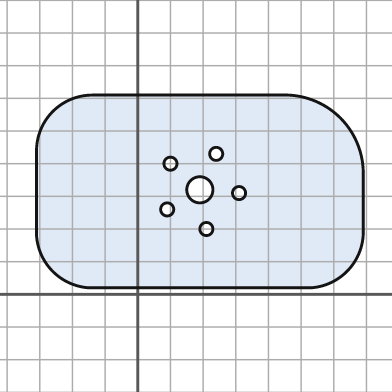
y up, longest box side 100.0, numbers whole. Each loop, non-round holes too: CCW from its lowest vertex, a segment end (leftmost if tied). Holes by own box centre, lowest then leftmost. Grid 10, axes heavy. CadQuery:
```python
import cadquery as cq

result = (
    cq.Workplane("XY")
    .moveTo(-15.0, 2.0)
    .lineTo(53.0, 2.0)
    .threePointArc((64.0, 7.0), (69.0, 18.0))
    .lineTo(69.0, 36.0)
    .threePointArc((62.0, 54.0), (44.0, 61.0))
    .lineTo(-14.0, 61.0)
    .threePointArc((-26.0, 56.0), (-31.0, 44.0))
    .lineTo(-31.0, 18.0)
    .threePointArc((-26.0, 7.0), (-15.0, 2.0))
    .close()
    .moveTo(21.0, 20.0)
    .circle(2.0)
    .moveTo(9.0, 26.0)
    .circle(2.0)
    .moveTo(31.0, 31.0)
    .circle(2.0)
    .moveTo(19.0, 32.0)
    .circle(4.0)
    .moveTo(10.0, 40.0)
    .circle(2.0)
    .moveTo(24.0, 43.0)
    .circle(2.0)
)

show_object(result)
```